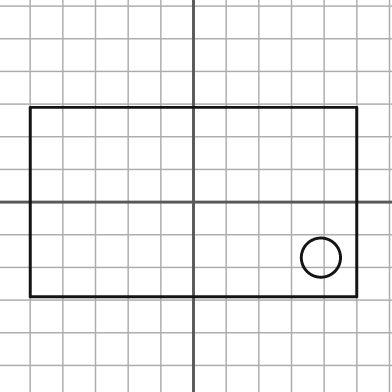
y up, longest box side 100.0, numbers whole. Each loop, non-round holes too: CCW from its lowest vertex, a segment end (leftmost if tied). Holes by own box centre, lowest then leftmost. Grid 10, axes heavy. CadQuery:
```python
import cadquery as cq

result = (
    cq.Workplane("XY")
    .moveTo(-50.0, -29.0)
    .lineTo(50.0, -29.0)
    .lineTo(50.0, 29.0)
    .lineTo(-50.0, 29.0)
    .close()
    .moveTo(39.0, -17.0)
    .circle(6.0)
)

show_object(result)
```